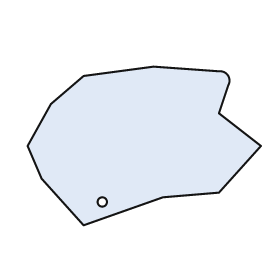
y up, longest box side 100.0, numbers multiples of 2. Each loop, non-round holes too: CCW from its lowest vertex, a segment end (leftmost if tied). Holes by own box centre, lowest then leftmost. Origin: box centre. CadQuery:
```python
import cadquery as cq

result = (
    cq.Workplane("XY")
    .moveTo(-26.0, -34.0)
    .lineTo(8.0, -22.0)
    .lineTo(32.0, -20.0)
    .lineTo(50.0, 0.0)
    .lineTo(32.0, 14.0)
    .lineTo(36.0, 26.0)
    .threePointArc((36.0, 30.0), (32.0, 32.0))
    .lineTo(4.0, 34.0)
    .lineTo(-26.0, 30.0)
    .lineTo(-40.0, 18.0)
    .lineTo(-50.0, 0.0)
    .lineTo(-44.0, -14.0)
    .close()
    .moveTo(-18.0, -24.0)
    .circle(2.0)
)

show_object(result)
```